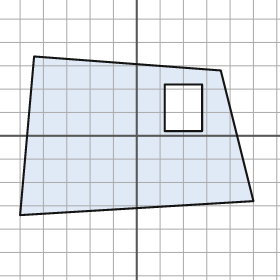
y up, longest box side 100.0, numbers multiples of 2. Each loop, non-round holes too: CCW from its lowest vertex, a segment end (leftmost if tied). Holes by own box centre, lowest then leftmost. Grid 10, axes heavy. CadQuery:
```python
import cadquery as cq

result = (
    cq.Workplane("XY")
    .moveTo(-50.0, -34.0)
    .lineTo(50.0, -28.0)
    .lineTo(36.0, 28.0)
    .lineTo(-44.0, 34.0)
    .close()
    .moveTo(12.0, 2.0)
    .lineTo(28.0, 2.0)
    .lineTo(28.0, 22.0)
    .lineTo(12.0, 22.0)
    .close()
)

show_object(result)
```